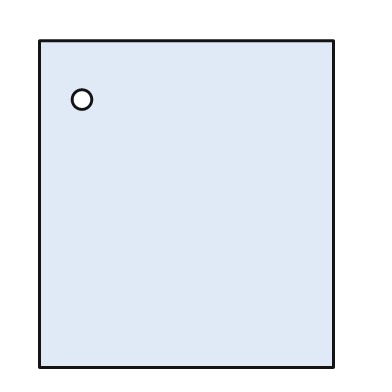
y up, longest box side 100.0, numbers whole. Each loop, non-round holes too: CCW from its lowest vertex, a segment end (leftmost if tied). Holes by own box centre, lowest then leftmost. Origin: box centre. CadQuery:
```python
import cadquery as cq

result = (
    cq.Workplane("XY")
    .moveTo(-45.0, -50.0)
    .lineTo(45.0, -50.0)
    .lineTo(45.0, 50.0)
    .lineTo(-45.0, 50.0)
    .close()
    .moveTo(-32.0, 32.0)
    .circle(3.0)
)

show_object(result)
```